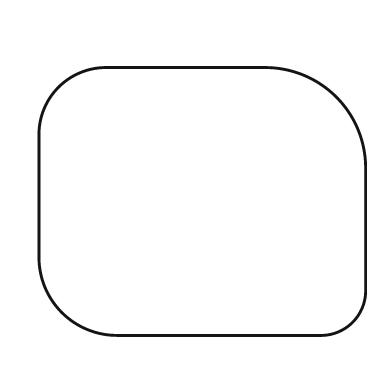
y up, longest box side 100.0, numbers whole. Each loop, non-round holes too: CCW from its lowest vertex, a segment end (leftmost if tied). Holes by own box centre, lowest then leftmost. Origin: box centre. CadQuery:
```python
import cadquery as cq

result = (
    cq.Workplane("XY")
    .moveTo(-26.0, -41.0)
    .lineTo(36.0, -41.0)
    .threePointArc((46.0, -37.0), (50.0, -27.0))
    .lineTo(50.0, 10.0)
    .threePointArc((41.0, 32.0), (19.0, 41.0))
    .lineTo(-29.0, 41.0)
    .threePointArc((-44.0, 35.0), (-50.0, 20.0))
    .lineTo(-50.0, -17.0)
    .threePointArc((-43.0, -34.0), (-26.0, -41.0))
    .close()
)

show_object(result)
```